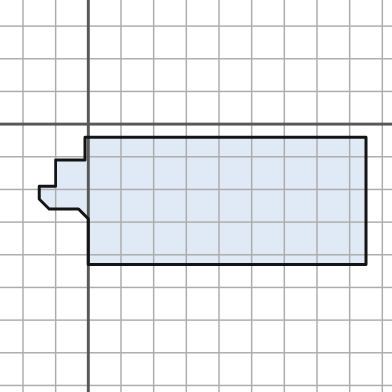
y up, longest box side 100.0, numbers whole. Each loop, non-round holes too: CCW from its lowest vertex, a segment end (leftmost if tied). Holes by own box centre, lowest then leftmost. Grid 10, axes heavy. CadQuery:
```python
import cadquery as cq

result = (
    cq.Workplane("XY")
    .moveTo(0.0, -43.0)
    .lineTo(85.0, -43.0)
    .lineTo(85.0, -4.0)
    .lineTo(-1.0, -4.0)
    .lineTo(-1.0, -11.0)
    .lineTo(-10.0, -11.0)
    .lineTo(-10.0, -19.0)
    .lineTo(-15.0, -19.0)
    .lineTo(-15.0, -23.0)
    .lineTo(-12.0, -26.0)
    .lineTo(-3.0, -26.0)
    .lineTo(0.0, -29.0)
    .close()
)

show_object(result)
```